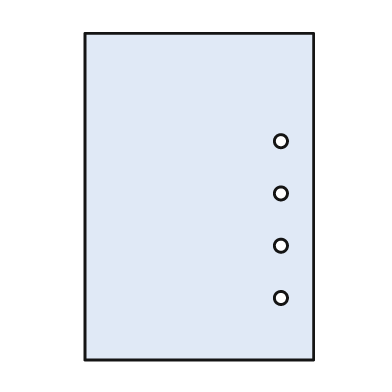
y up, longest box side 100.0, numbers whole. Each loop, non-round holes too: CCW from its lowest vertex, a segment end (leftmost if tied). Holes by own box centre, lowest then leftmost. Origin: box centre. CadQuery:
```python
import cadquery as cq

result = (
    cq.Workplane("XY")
    .moveTo(-35.0, -50.0)
    .lineTo(35.0, -50.0)
    .lineTo(35.0, 50.0)
    .lineTo(-35.0, 50.0)
    .close()
    .moveTo(25.0, -31.0)
    .circle(2.0)
    .moveTo(25.0, -15.0)
    .circle(2.0)
    .moveTo(25.0, 1.0)
    .circle(2.0)
    .moveTo(25.0, 17.0)
    .circle(2.0)
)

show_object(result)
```